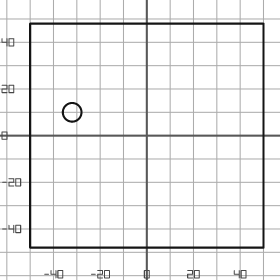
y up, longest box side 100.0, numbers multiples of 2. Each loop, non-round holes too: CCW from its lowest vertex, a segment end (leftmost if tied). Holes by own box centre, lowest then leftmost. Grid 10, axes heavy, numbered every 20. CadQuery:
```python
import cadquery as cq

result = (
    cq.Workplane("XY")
    .moveTo(-50.0, -48.0)
    .lineTo(50.0, -48.0)
    .lineTo(50.0, 48.0)
    .lineTo(-50.0, 48.0)
    .close()
    .moveTo(-32.0, 10.0)
    .circle(4.0)
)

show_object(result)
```